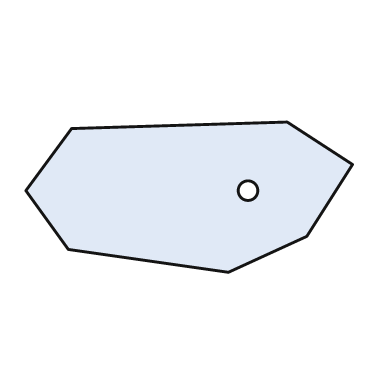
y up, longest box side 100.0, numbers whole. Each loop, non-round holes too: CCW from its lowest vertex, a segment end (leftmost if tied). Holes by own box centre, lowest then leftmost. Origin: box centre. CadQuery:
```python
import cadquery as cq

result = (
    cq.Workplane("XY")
    .moveTo(12.0, -23.0)
    .lineTo(36.0, -12.0)
    .lineTo(50.0, 10.0)
    .lineTo(30.0, 23.0)
    .lineTo(-36.0, 21.0)
    .lineTo(-50.0, 2.0)
    .lineTo(-37.0, -16.0)
    .close()
    .moveTo(18.0, 2.0)
    .circle(3.0)
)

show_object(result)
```